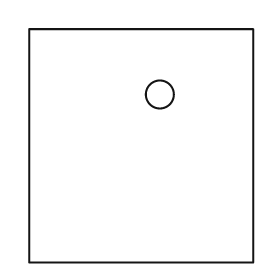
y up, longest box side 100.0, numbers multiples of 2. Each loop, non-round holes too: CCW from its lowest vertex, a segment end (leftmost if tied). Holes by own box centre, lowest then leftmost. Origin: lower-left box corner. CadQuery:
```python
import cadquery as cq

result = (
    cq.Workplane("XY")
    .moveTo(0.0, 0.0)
    .lineTo(96.0, 0.0)
    .lineTo(96.0, 100.0)
    .lineTo(0.0, 100.0)
    .close()
    .moveTo(56.0, 72.0)
    .circle(6.0)
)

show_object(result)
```